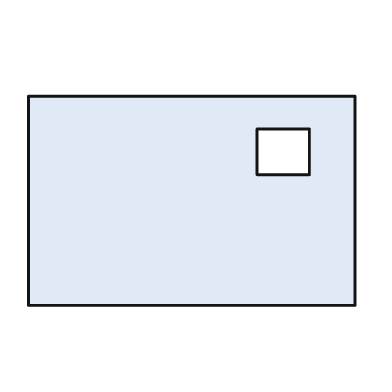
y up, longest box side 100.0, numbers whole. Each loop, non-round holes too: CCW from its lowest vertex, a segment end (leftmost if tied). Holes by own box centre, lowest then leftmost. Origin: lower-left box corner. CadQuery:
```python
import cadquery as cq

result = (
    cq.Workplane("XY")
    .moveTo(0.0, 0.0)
    .lineTo(100.0, 0.0)
    .lineTo(100.0, 64.0)
    .lineTo(0.0, 64.0)
    .close()
    .moveTo(70.0, 40.0)
    .lineTo(86.0, 40.0)
    .lineTo(86.0, 54.0)
    .lineTo(70.0, 54.0)
    .close()
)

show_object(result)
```